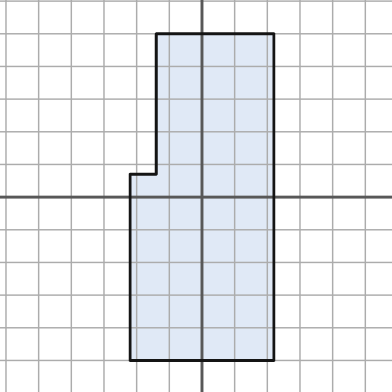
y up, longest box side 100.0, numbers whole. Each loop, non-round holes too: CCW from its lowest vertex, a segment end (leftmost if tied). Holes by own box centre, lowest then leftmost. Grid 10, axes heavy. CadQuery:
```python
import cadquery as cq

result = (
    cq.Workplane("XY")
    .moveTo(-22.0, -50.0)
    .lineTo(22.0, -50.0)
    .lineTo(22.0, 50.0)
    .lineTo(-14.0, 50.0)
    .lineTo(-14.0, 7.0)
    .lineTo(-22.0, 7.0)
    .close()
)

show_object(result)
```